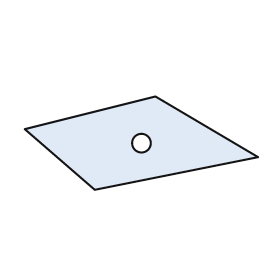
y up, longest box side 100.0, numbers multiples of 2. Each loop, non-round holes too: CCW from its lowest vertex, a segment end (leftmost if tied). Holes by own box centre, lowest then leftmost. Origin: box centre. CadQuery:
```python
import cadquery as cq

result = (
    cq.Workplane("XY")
    .moveTo(-20.0, -20.0)
    .lineTo(50.0, -6.0)
    .lineTo(6.0, 20.0)
    .lineTo(-50.0, 6.0)
    .close()
    .moveTo(0.0, 0.0)
    .circle(4.0)
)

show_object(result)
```